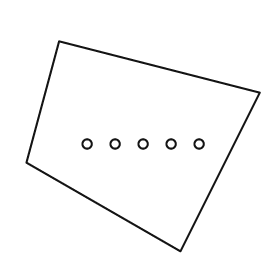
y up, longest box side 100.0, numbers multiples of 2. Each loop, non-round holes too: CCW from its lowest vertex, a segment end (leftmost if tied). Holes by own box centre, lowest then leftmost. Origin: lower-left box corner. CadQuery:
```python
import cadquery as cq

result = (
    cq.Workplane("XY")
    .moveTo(66.0, 0.0)
    .lineTo(100.0, 68.0)
    .lineTo(14.0, 90.0)
    .lineTo(0.0, 38.0)
    .close()
    .moveTo(26.0, 46.0)
    .circle(2.0)
    .moveTo(38.0, 46.0)
    .circle(2.0)
    .moveTo(50.0, 46.0)
    .circle(2.0)
    .moveTo(62.0, 46.0)
    .circle(2.0)
    .moveTo(74.0, 46.0)
    .circle(2.0)
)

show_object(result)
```